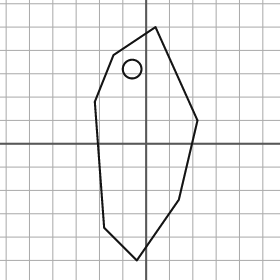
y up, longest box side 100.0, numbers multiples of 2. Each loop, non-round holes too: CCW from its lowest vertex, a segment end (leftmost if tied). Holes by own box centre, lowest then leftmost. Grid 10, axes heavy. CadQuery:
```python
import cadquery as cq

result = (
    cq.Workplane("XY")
    .moveTo(-4.0, -50.0)
    .lineTo(14.0, -24.0)
    .lineTo(22.0, 10.0)
    .lineTo(4.0, 50.0)
    .lineTo(-14.0, 38.0)
    .lineTo(-22.0, 18.0)
    .lineTo(-18.0, -36.0)
    .close()
    .moveTo(-6.0, 32.0)
    .circle(4.0)
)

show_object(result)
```